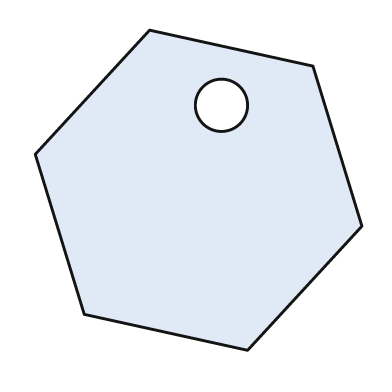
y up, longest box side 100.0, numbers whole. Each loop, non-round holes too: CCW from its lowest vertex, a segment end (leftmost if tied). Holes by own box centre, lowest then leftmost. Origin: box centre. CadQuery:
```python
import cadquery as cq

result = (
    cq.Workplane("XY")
    .moveTo(15.0, -49.0)
    .lineTo(50.0, -11.0)
    .lineTo(35.0, 38.0)
    .lineTo(-15.0, 49.0)
    .lineTo(-50.0, 11.0)
    .lineTo(-35.0, -38.0)
    .close()
    .moveTo(7.0, 26.0)
    .circle(8.0)
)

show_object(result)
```